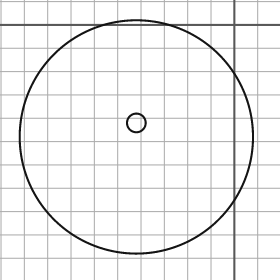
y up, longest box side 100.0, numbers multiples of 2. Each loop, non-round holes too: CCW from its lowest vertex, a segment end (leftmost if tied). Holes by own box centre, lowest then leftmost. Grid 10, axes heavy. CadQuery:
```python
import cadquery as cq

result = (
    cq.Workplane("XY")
    .moveTo(-42.0, -48.0)
    .circle(50.0)
    .moveTo(-42.0, -42.0)
    .circle(4.0)
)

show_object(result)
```